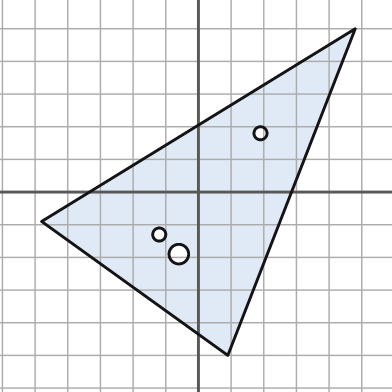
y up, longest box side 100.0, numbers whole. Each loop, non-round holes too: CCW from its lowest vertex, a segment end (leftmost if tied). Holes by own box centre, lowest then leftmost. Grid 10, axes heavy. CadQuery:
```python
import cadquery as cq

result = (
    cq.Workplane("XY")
    .moveTo(9.0, -50.0)
    .lineTo(48.0, 50.0)
    .lineTo(-48.0, -9.0)
    .close()
    .moveTo(-6.0, -19.0)
    .circle(3.0)
    .moveTo(-12.0, -13.0)
    .circle(2.0)
    .moveTo(19.0, 18.0)
    .circle(2.0)
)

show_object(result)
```